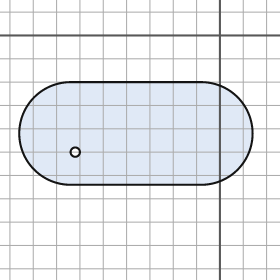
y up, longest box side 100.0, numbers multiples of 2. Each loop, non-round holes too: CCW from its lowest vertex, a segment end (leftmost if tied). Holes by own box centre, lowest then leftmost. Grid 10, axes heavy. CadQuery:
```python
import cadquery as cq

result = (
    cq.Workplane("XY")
    .moveTo(-64.0, -64.0)
    .lineTo(-8.0, -64.0)
    .threePointArc((14.0, -42.0), (-8.0, -20.0))
    .lineTo(-64.0, -20.0)
    .threePointArc((-86.0, -42.0), (-64.0, -64.0))
    .close()
    .moveTo(-62.0, -50.0)
    .circle(2.0)
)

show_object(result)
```